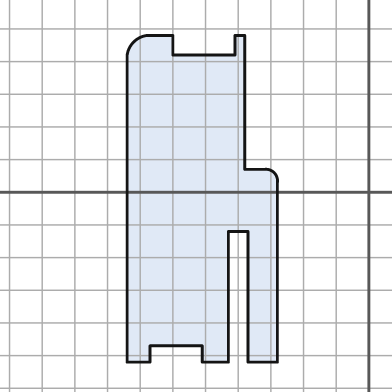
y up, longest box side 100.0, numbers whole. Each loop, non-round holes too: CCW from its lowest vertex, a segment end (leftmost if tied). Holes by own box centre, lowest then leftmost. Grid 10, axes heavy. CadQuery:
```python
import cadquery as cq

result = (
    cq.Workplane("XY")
    .moveTo(-74.0, -52.0)
    .lineTo(-67.0, -52.0)
    .lineTo(-67.0, -47.0)
    .lineTo(-51.0, -47.0)
    .lineTo(-51.0, -52.0)
    .lineTo(-43.0, -52.0)
    .lineTo(-43.0, -12.0)
    .lineTo(-37.0, -12.0)
    .lineTo(-37.0, -52.0)
    .lineTo(-28.0, -52.0)
    .lineTo(-28.0, 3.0)
    .threePointArc((-29.0, 6.0), (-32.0, 7.0))
    .lineTo(-38.0, 7.0)
    .lineTo(-38.0, 48.0)
    .lineTo(-41.0, 48.0)
    .lineTo(-41.0, 42.0)
    .lineTo(-60.0, 42.0)
    .lineTo(-60.0, 48.0)
    .lineTo(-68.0, 48.0)
    .threePointArc((-72.0, 46.0), (-74.0, 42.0))
    .close()
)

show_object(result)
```